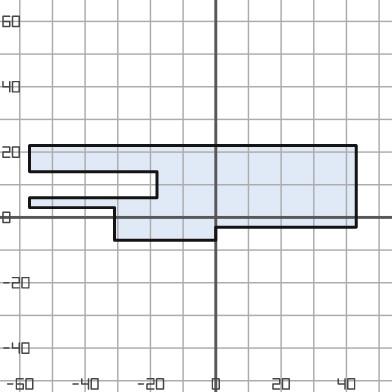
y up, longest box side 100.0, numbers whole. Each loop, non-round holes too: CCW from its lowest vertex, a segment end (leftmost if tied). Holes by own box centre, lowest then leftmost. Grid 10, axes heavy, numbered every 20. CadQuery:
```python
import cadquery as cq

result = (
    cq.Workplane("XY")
    .moveTo(-31.0, -7.0)
    .lineTo(0.0, -7.0)
    .lineTo(0.0, -3.0)
    .lineTo(43.0, -3.0)
    .lineTo(43.0, 22.0)
    .lineTo(-57.0, 22.0)
    .lineTo(-57.0, 14.0)
    .lineTo(-18.0, 14.0)
    .lineTo(-18.0, 6.0)
    .lineTo(-57.0, 6.0)
    .lineTo(-57.0, 3.0)
    .lineTo(-31.0, 3.0)
    .close()
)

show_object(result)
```